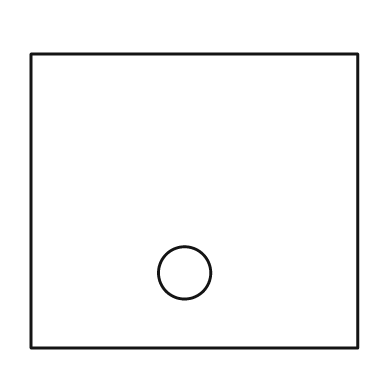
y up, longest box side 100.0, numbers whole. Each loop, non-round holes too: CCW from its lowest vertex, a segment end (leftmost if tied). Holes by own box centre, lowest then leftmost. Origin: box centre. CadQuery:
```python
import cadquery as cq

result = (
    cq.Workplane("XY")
    .moveTo(-50.0, -45.0)
    .lineTo(50.0, -45.0)
    .lineTo(50.0, 45.0)
    .lineTo(-50.0, 45.0)
    .close()
    .moveTo(-3.0, -22.0)
    .circle(8.0)
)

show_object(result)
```